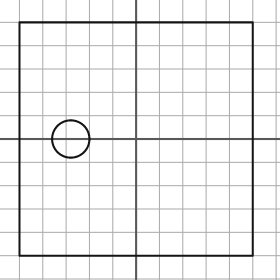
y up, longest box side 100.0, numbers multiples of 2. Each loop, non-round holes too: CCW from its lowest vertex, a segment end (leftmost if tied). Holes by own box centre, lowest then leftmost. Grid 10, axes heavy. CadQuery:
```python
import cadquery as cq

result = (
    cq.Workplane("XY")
    .moveTo(-50.0, -50.0)
    .lineTo(50.0, -50.0)
    .lineTo(50.0, 50.0)
    .lineTo(-50.0, 50.0)
    .close()
    .moveTo(-28.0, 0.0)
    .circle(8.0)
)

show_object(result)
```